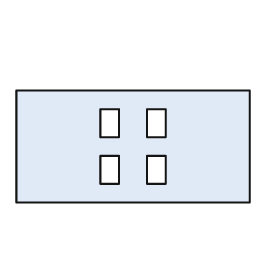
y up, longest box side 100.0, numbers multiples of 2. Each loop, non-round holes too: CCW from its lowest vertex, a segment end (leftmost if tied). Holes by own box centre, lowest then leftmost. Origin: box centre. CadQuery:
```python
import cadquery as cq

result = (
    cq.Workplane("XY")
    .moveTo(-50.0, -24.0)
    .lineTo(50.0, -24.0)
    .lineTo(50.0, 24.0)
    .lineTo(-50.0, 24.0)
    .close()
    .moveTo(-14.0, -16.0)
    .lineTo(-6.0, -16.0)
    .lineTo(-6.0, -4.0)
    .lineTo(-14.0, -4.0)
    .close()
    .moveTo(6.0, -16.0)
    .lineTo(14.0, -16.0)
    .lineTo(14.0, -4.0)
    .lineTo(6.0, -4.0)
    .close()
    .moveTo(-14.0, 4.0)
    .lineTo(-6.0, 4.0)
    .lineTo(-6.0, 16.0)
    .lineTo(-14.0, 16.0)
    .close()
    .moveTo(6.0, 4.0)
    .lineTo(14.0, 4.0)
    .lineTo(14.0, 16.0)
    .lineTo(6.0, 16.0)
    .close()
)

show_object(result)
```